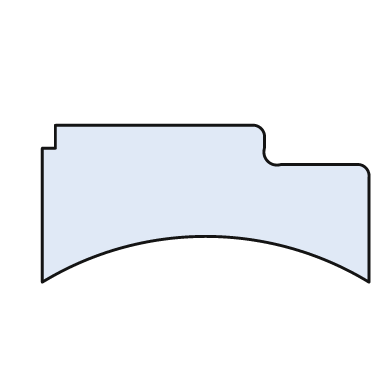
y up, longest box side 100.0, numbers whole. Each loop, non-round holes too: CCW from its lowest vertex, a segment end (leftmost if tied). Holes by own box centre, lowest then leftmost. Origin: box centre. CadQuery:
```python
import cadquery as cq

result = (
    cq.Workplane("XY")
    .moveTo(-50.0, -24.0)
    .threePointArc((0.0, -10.0), (50.0, -24.0))
    .lineTo(50.0, 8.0)
    .threePointArc((49.0, 11.0), (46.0, 12.0))
    .lineTo(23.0, 12.0)
    .threePointArc((19.0, 13.0), (18.0, 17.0))
    .lineTo(18.0, 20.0)
    .threePointArc((17.0, 23.0), (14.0, 24.0))
    .lineTo(-46.0, 24.0)
    .lineTo(-46.0, 17.0)
    .lineTo(-50.0, 17.0)
    .close()
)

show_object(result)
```